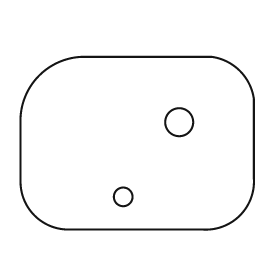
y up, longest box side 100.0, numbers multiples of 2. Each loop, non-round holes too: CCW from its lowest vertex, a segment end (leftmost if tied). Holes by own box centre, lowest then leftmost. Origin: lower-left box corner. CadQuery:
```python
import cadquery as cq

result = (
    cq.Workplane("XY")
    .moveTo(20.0, 0.0)
    .lineTo(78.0, 0.0)
    .threePointArc((94.0, 6.0), (100.0, 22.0))
    .lineTo(100.0, 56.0)
    .threePointArc((94.0, 68.0), (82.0, 74.0))
    .lineTo(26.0, 74.0)
    .threePointArc((8.0, 66.0), (0.0, 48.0))
    .lineTo(0.0, 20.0)
    .threePointArc((6.0, 6.0), (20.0, 0.0))
    .close()
    .moveTo(44.0, 14.0)
    .circle(4.0)
    .moveTo(68.0, 46.0)
    .circle(6.0)
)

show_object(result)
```